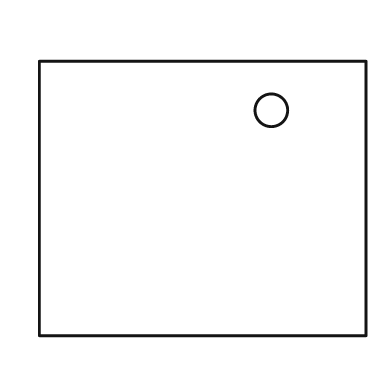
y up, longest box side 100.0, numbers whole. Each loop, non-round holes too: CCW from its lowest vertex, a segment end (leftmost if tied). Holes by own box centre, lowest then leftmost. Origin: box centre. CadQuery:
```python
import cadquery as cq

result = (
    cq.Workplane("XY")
    .moveTo(-50.0, -42.0)
    .lineTo(50.0, -42.0)
    .lineTo(50.0, 42.0)
    .lineTo(-50.0, 42.0)
    .close()
    .moveTo(21.0, 27.0)
    .circle(5.0)
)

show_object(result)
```